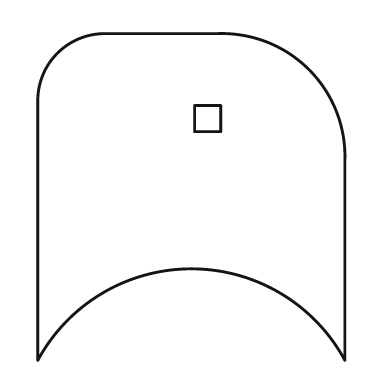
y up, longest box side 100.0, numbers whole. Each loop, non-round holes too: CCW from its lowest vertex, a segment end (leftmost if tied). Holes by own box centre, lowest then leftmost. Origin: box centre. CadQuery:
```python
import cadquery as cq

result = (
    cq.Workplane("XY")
    .moveTo(-47.0, -50.0)
    .threePointArc((0.0, -22.0), (47.0, -50.0))
    .lineTo(47.0, 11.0)
    .threePointArc((36.0, 39.0), (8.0, 50.0))
    .lineTo(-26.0, 50.0)
    .threePointArc((-41.0, 44.0), (-47.0, 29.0))
    .close()
    .moveTo(1.0, 20.0)
    .lineTo(9.0, 20.0)
    .lineTo(9.0, 28.0)
    .lineTo(1.0, 28.0)
    .close()
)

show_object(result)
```